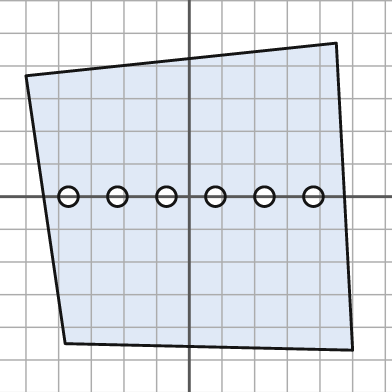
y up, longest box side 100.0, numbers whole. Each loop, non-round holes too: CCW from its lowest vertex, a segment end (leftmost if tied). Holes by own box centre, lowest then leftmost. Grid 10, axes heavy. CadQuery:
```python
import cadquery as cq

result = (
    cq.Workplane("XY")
    .moveTo(50.0, -47.0)
    .lineTo(45.0, 47.0)
    .lineTo(-50.0, 37.0)
    .lineTo(-38.0, -45.0)
    .close()
    .moveTo(-37.0, 0.0)
    .circle(3.0)
    .moveTo(-22.0, 0.0)
    .circle(3.0)
    .moveTo(-7.0, 0.0)
    .circle(3.0)
    .moveTo(8.0, 0.0)
    .circle(3.0)
    .moveTo(23.0, 0.0)
    .circle(3.0)
    .moveTo(38.0, 0.0)
    .circle(3.0)
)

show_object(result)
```